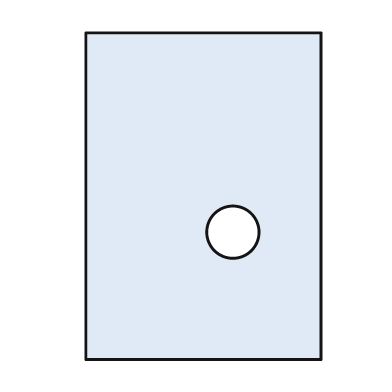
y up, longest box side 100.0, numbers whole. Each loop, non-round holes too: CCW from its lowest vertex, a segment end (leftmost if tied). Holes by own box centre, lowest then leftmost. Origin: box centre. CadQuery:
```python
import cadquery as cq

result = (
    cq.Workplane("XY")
    .moveTo(-36.0, -50.0)
    .lineTo(36.0, -50.0)
    .lineTo(36.0, 50.0)
    .lineTo(-36.0, 50.0)
    .close()
    .moveTo(9.0, -11.0)
    .circle(8.0)
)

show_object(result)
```